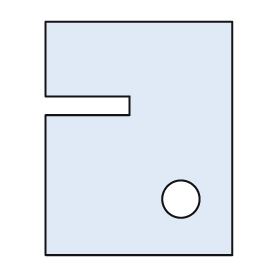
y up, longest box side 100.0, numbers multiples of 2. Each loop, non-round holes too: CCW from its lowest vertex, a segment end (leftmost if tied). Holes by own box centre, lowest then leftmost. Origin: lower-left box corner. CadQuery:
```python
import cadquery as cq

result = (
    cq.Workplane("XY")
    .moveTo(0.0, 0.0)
    .lineTo(80.0, 0.0)
    .lineTo(80.0, 100.0)
    .lineTo(0.0, 100.0)
    .lineTo(0.0, 68.0)
    .lineTo(36.0, 68.0)
    .lineTo(36.0, 60.0)
    .lineTo(0.0, 60.0)
    .close()
    .moveTo(58.0, 24.0)
    .circle(8.0)
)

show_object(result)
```